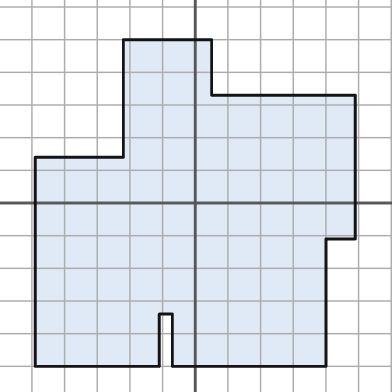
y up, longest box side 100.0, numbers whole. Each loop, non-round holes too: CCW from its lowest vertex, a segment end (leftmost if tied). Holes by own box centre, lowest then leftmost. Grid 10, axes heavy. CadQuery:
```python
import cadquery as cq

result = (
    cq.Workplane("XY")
    .moveTo(-49.0, -50.0)
    .lineTo(-11.0, -50.0)
    .lineTo(-11.0, -34.0)
    .lineTo(-7.0, -34.0)
    .lineTo(-7.0, -50.0)
    .lineTo(40.0, -50.0)
    .lineTo(40.0, -11.0)
    .lineTo(49.0, -11.0)
    .lineTo(49.0, 33.0)
    .lineTo(5.0, 33.0)
    .lineTo(5.0, 50.0)
    .lineTo(-22.0, 50.0)
    .lineTo(-22.0, 14.0)
    .lineTo(-49.0, 14.0)
    .close()
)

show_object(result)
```